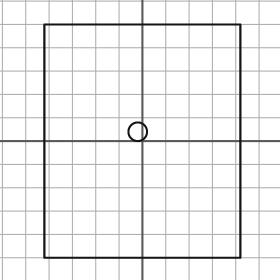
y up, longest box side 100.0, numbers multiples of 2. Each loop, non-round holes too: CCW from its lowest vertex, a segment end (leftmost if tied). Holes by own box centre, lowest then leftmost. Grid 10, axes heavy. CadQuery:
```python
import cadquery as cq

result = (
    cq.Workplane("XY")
    .moveTo(-42.0, -50.0)
    .lineTo(42.0, -50.0)
    .lineTo(42.0, 50.0)
    .lineTo(-42.0, 50.0)
    .close()
    .moveTo(-2.0, 4.0)
    .circle(4.0)
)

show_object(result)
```